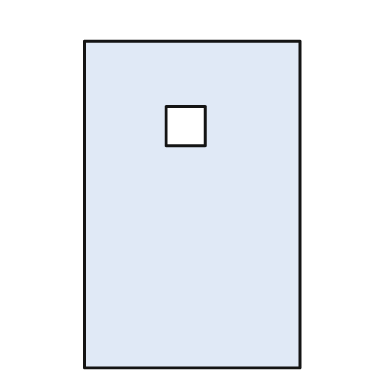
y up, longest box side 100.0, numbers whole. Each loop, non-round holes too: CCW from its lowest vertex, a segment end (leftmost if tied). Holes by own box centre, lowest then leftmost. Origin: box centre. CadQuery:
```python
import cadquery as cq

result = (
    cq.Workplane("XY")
    .moveTo(-33.0, -50.0)
    .lineTo(33.0, -50.0)
    .lineTo(33.0, 50.0)
    .lineTo(-33.0, 50.0)
    .close()
    .moveTo(-8.0, 18.0)
    .lineTo(4.0, 18.0)
    .lineTo(4.0, 30.0)
    .lineTo(-8.0, 30.0)
    .close()
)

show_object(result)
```